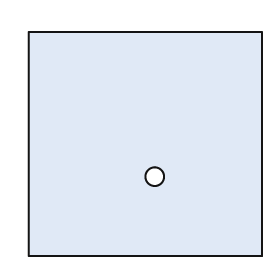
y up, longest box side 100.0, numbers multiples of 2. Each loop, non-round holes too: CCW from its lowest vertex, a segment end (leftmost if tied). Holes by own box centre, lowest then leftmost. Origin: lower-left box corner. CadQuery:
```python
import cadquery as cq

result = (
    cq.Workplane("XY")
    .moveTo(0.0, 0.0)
    .lineTo(100.0, 0.0)
    .lineTo(100.0, 96.0)
    .lineTo(0.0, 96.0)
    .close()
    .moveTo(54.0, 34.0)
    .circle(4.0)
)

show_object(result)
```